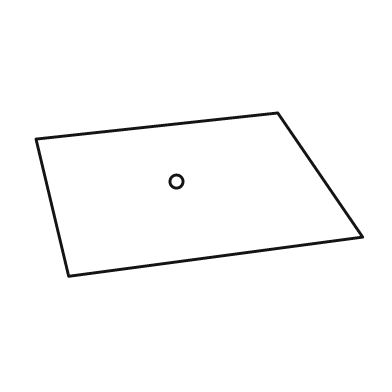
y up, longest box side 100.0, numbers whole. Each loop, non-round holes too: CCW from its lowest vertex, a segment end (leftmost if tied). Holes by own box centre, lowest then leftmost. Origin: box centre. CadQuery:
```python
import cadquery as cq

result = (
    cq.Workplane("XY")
    .moveTo(-40.0, -25.0)
    .lineTo(50.0, -13.0)
    .lineTo(24.0, 25.0)
    .lineTo(-50.0, 17.0)
    .close()
    .moveTo(-7.0, 4.0)
    .circle(2.0)
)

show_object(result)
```